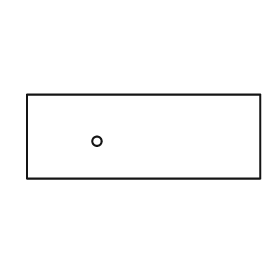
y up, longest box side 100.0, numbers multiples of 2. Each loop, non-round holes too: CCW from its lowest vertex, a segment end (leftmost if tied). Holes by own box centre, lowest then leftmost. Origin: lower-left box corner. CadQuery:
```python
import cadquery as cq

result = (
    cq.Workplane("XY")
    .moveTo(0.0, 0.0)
    .lineTo(100.0, 0.0)
    .lineTo(100.0, 36.0)
    .lineTo(0.0, 36.0)
    .close()
    .moveTo(30.0, 16.0)
    .circle(2.0)
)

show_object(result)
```